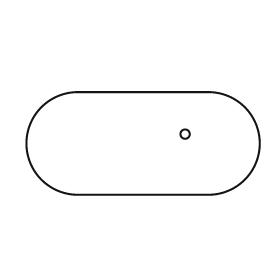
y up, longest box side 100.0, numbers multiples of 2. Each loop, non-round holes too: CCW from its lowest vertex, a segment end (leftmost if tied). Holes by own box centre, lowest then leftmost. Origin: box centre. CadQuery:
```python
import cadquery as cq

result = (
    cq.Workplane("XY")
    .moveTo(-28.0, -22.0)
    .lineTo(28.0, -22.0)
    .threePointArc((50.0, 0.0), (28.0, 22.0))
    .lineTo(-28.0, 22.0)
    .threePointArc((-50.0, 0.0), (-28.0, -22.0))
    .close()
    .moveTo(18.0, 4.0)
    .circle(2.0)
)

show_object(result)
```